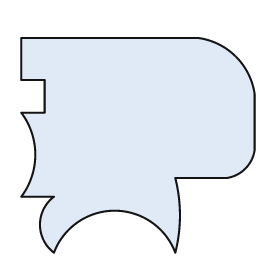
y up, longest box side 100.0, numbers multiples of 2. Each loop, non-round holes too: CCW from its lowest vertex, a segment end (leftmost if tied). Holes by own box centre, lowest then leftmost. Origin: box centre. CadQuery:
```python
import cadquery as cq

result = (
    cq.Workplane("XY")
    .moveTo(-36.0, -46.0)
    .threePointArc((-10.0, -28.0), (16.0, -46.0))
    .threePointArc((18.0, -30.0), (16.0, -14.0))
    .lineTo(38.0, -14.0)
    .threePointArc((46.0, -10.0), (50.0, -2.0))
    .lineTo(50.0, 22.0)
    .threePointArc((42.0, 38.0), (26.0, 46.0))
    .lineTo(-50.0, 46.0)
    .lineTo(-50.0, 28.0)
    .lineTo(-40.0, 28.0)
    .lineTo(-40.0, 14.0)
    .lineTo(-50.0, 14.0)
    .threePointArc((-44.0, -4.0), (-50.0, -22.0))
    .lineTo(-36.0, -22.0)
    .threePointArc((-42.0, -34.0), (-36.0, -46.0))
    .close()
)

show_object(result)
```